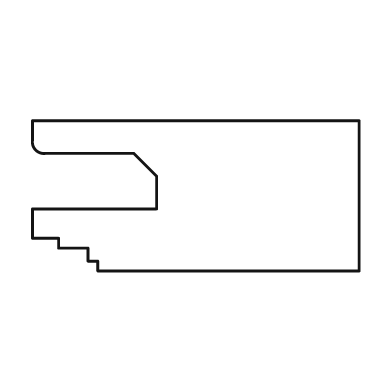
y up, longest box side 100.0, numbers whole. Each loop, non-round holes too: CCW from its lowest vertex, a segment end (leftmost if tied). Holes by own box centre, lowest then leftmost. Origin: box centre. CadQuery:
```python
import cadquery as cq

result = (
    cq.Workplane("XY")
    .moveTo(-30.0, -23.0)
    .lineTo(50.0, -23.0)
    .lineTo(50.0, 23.0)
    .lineTo(-50.0, 23.0)
    .lineTo(-50.0, 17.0)
    .threePointArc((-49.0, 14.0), (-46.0, 13.0))
    .lineTo(-19.0, 13.0)
    .lineTo(-12.0, 6.0)
    .lineTo(-12.0, -4.0)
    .lineTo(-50.0, -4.0)
    .lineTo(-50.0, -13.0)
    .lineTo(-42.0, -13.0)
    .lineTo(-42.0, -16.0)
    .lineTo(-33.0, -16.0)
    .lineTo(-33.0, -20.0)
    .lineTo(-30.0, -20.0)
    .close()
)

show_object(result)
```